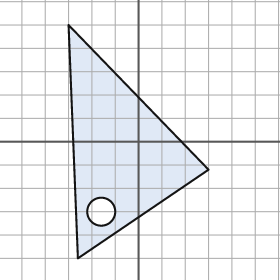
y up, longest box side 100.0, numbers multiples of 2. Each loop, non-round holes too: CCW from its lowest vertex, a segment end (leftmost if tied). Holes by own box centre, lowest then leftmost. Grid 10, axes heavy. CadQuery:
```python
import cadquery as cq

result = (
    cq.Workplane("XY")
    .moveTo(-26.0, -50.0)
    .lineTo(30.0, -12.0)
    .lineTo(-30.0, 50.0)
    .close()
    .moveTo(-16.0, -30.0)
    .circle(6.0)
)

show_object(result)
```